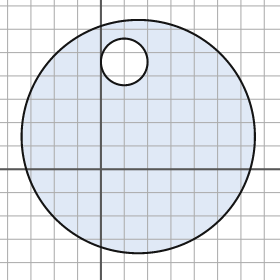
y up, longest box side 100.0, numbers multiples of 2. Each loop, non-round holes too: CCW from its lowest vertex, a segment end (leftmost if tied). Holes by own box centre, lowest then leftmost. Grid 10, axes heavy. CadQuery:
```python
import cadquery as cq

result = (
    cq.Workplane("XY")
    .moveTo(16.0, 14.0)
    .circle(50.0)
    .moveTo(10.0, 46.0)
    .circle(10.0)
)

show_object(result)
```